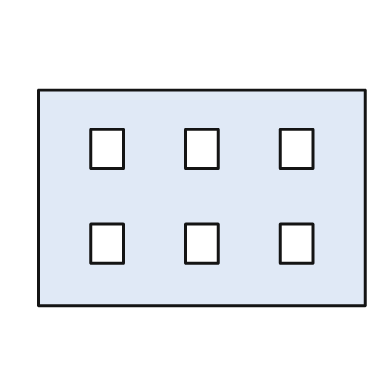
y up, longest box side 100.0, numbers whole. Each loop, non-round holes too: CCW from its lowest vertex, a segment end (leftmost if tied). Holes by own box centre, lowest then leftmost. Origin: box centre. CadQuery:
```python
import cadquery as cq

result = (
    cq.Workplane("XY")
    .moveTo(-50.0, -33.0)
    .lineTo(50.0, -33.0)
    .lineTo(50.0, 33.0)
    .lineTo(-50.0, 33.0)
    .close()
    .moveTo(-34.0, -20.0)
    .lineTo(-24.0, -20.0)
    .lineTo(-24.0, -8.0)
    .lineTo(-34.0, -8.0)
    .close()
    .moveTo(-5.0, -20.0)
    .lineTo(5.0, -20.0)
    .lineTo(5.0, -8.0)
    .lineTo(-5.0, -8.0)
    .close()
    .moveTo(24.0, -20.0)
    .lineTo(34.0, -20.0)
    .lineTo(34.0, -8.0)
    .lineTo(24.0, -8.0)
    .close()
    .moveTo(-34.0, 9.0)
    .lineTo(-24.0, 9.0)
    .lineTo(-24.0, 21.0)
    .lineTo(-34.0, 21.0)
    .close()
    .moveTo(-5.0, 9.0)
    .lineTo(5.0, 9.0)
    .lineTo(5.0, 21.0)
    .lineTo(-5.0, 21.0)
    .close()
    .moveTo(24.0, 9.0)
    .lineTo(34.0, 9.0)
    .lineTo(34.0, 21.0)
    .lineTo(24.0, 21.0)
    .close()
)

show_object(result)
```